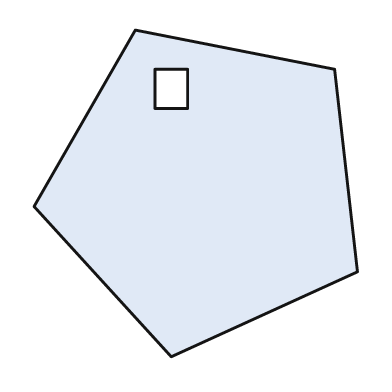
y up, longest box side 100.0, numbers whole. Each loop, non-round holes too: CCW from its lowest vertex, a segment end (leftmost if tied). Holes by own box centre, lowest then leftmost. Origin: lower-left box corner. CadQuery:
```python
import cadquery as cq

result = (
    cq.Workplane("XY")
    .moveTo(42.0, 0.0)
    .lineTo(99.0, 26.0)
    .lineTo(92.0, 88.0)
    .lineTo(31.0, 100.0)
    .lineTo(0.0, 46.0)
    .close()
    .moveTo(37.0, 76.0)
    .lineTo(47.0, 76.0)
    .lineTo(47.0, 88.0)
    .lineTo(37.0, 88.0)
    .close()
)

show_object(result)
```